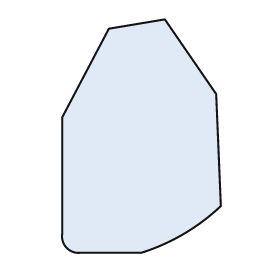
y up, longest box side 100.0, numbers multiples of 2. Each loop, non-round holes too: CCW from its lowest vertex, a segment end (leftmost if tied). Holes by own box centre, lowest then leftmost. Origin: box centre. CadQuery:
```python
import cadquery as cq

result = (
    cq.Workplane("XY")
    .moveTo(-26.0, -50.0)
    .lineTo(0.0, -50.0)
    .threePointArc((18.0, -42.0), (34.0, -30.0))
    .lineTo(32.0, 18.0)
    .lineTo(10.0, 50.0)
    .lineTo(-14.0, 46.0)
    .lineTo(-34.0, 8.0)
    .lineTo(-34.0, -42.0)
    .threePointArc((-32.0, -48.0), (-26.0, -50.0))
    .close()
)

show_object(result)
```